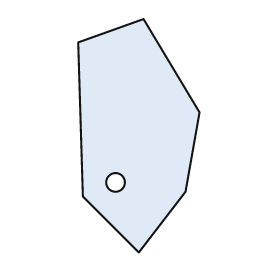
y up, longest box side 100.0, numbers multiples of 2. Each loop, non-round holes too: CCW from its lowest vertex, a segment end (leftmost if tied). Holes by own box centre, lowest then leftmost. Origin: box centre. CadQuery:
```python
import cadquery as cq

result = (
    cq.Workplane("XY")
    .moveTo(0.0, -50.0)
    .lineTo(20.0, -24.0)
    .lineTo(26.0, 10.0)
    .lineTo(2.0, 50.0)
    .lineTo(-26.0, 40.0)
    .lineTo(-24.0, -26.0)
    .close()
    .moveTo(-10.0, -20.0)
    .circle(4.0)
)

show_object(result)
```